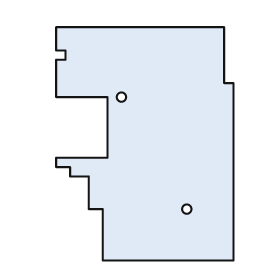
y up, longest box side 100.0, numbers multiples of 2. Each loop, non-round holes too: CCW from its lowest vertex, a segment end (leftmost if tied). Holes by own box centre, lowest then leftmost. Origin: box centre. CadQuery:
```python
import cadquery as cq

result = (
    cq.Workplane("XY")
    .moveTo(-18.0, -50.0)
    .lineTo(38.0, -50.0)
    .lineTo(38.0, 26.0)
    .lineTo(34.0, 26.0)
    .lineTo(34.0, 50.0)
    .lineTo(-38.0, 50.0)
    .lineTo(-38.0, 40.0)
    .lineTo(-34.0, 40.0)
    .lineTo(-34.0, 36.0)
    .lineTo(-38.0, 36.0)
    .lineTo(-38.0, 20.0)
    .lineTo(-16.0, 20.0)
    .lineTo(-16.0, -6.0)
    .lineTo(-38.0, -6.0)
    .lineTo(-38.0, -10.0)
    .lineTo(-32.0, -10.0)
    .lineTo(-32.0, -14.0)
    .lineTo(-24.0, -14.0)
    .lineTo(-24.0, -28.0)
    .lineTo(-18.0, -28.0)
    .close()
    .moveTo(18.0, -28.0)
    .circle(2.0)
    .moveTo(-10.0, 20.0)
    .circle(2.0)
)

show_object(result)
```